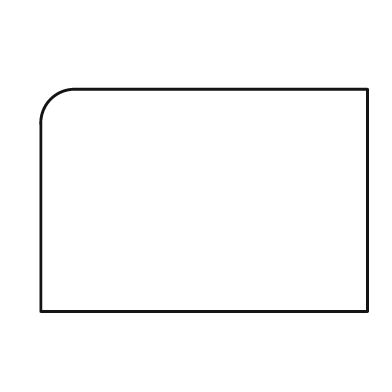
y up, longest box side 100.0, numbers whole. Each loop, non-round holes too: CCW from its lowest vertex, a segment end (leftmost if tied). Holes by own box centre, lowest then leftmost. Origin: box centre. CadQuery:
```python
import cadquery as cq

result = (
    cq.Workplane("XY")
    .moveTo(-50.0, -34.0)
    .lineTo(50.0, -34.0)
    .lineTo(50.0, 34.0)
    .lineTo(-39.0, 34.0)
    .threePointArc((-47.0, 31.0), (-50.0, 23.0))
    .close()
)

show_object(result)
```